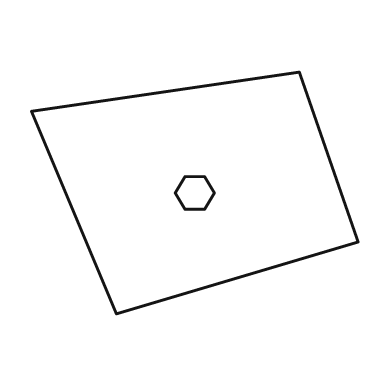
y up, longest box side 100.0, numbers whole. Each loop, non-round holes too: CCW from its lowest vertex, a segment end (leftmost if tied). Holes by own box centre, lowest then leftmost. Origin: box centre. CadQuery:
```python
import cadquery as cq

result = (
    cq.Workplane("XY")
    .moveTo(-24.0, -37.0)
    .lineTo(50.0, -15.0)
    .lineTo(32.0, 37.0)
    .lineTo(-50.0, 25.0)
    .close()
    .moveTo(-3.0, -5.0)
    .lineTo(3.0, -5.0)
    .lineTo(6.0, 0.0)
    .lineTo(3.0, 5.0)
    .lineTo(-3.0, 5.0)
    .lineTo(-6.0, 0.0)
    .close()
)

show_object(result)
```